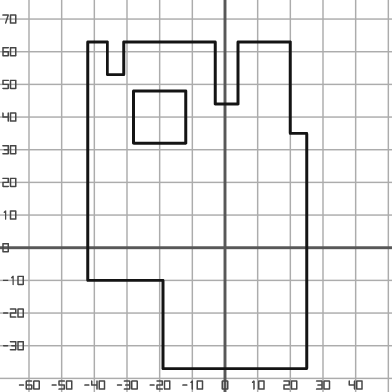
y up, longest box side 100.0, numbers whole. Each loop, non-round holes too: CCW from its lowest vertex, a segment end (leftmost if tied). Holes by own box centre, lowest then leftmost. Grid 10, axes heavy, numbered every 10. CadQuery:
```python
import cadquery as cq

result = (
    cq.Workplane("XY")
    .moveTo(-19.0, -37.0)
    .lineTo(25.0, -37.0)
    .lineTo(25.0, 35.0)
    .lineTo(20.0, 35.0)
    .lineTo(20.0, 63.0)
    .lineTo(4.0, 63.0)
    .lineTo(4.0, 44.0)
    .lineTo(-3.0, 44.0)
    .lineTo(-3.0, 63.0)
    .lineTo(-31.0, 63.0)
    .lineTo(-31.0, 53.0)
    .lineTo(-36.0, 53.0)
    .lineTo(-36.0, 63.0)
    .lineTo(-42.0, 63.0)
    .lineTo(-42.0, -10.0)
    .lineTo(-19.0, -10.0)
    .close()
    .moveTo(-28.0, 32.0)
    .lineTo(-12.0, 32.0)
    .lineTo(-12.0, 48.0)
    .lineTo(-28.0, 48.0)
    .close()
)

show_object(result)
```